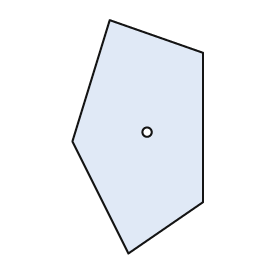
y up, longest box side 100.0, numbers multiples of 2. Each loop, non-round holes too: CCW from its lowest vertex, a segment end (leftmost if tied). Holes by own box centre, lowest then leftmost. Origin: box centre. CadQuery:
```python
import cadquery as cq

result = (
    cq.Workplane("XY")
    .moveTo(-4.0, -50.0)
    .lineTo(28.0, -28.0)
    .lineTo(28.0, 36.0)
    .lineTo(-12.0, 50.0)
    .lineTo(-28.0, -2.0)
    .close()
    .moveTo(4.0, 2.0)
    .circle(2.0)
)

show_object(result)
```